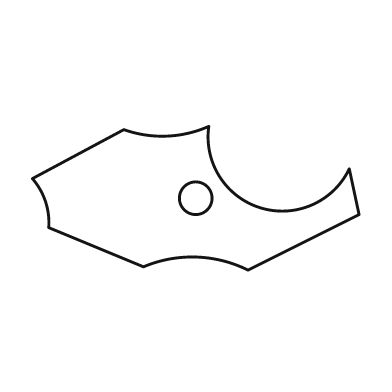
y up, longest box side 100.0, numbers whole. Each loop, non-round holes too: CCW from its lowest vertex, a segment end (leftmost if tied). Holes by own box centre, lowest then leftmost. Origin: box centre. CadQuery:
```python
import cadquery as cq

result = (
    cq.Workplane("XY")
    .moveTo(16.0, -22.0)
    .lineTo(50.0, -5.0)
    .lineTo(47.0, 9.0)
    .threePointArc((20.0, -3.0), (4.0, 22.0))
    .threePointArc((-9.0, 19.0), (-22.0, 21.0))
    .lineTo(-50.0, 6.0)
    .threePointArc((-46.0, -1.0), (-45.0, -9.0))
    .lineTo(-16.0, -21.0)
    .threePointArc((0.0, -18.0), (16.0, -22.0))
    .close()
    .moveTo(0.0, 0.0)
    .circle(5.0)
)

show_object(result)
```